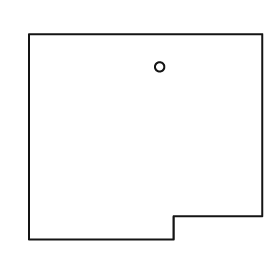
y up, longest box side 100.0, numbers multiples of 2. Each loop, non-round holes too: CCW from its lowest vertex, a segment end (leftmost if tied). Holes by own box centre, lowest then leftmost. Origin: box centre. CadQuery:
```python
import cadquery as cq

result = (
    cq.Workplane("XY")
    .moveTo(-50.0, -44.0)
    .lineTo(12.0, -44.0)
    .lineTo(12.0, -34.0)
    .lineTo(50.0, -34.0)
    .lineTo(50.0, 44.0)
    .lineTo(-50.0, 44.0)
    .close()
    .moveTo(6.0, 30.0)
    .circle(2.0)
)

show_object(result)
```